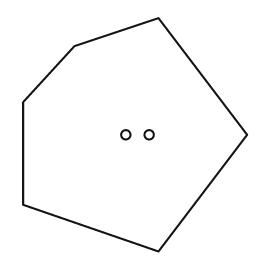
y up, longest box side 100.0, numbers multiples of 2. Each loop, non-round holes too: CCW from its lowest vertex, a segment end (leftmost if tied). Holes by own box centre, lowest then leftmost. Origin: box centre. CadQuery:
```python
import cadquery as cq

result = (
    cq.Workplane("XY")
    .moveTo(10.0, -50.0)
    .lineTo(48.0, 0.0)
    .lineTo(10.0, 50.0)
    .lineTo(-26.0, 38.0)
    .lineTo(-48.0, 14.0)
    .lineTo(-48.0, -30.0)
    .close()
    .moveTo(-4.0, 0.0)
    .circle(2.0)
    .moveTo(6.0, 0.0)
    .circle(2.0)
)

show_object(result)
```